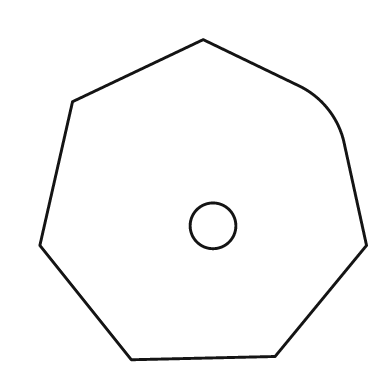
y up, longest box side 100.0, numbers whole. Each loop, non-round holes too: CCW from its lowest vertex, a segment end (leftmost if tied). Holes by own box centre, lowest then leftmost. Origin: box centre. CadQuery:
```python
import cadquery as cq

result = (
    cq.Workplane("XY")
    .moveTo(-22.0, -49.0)
    .lineTo(22.0, -48.0)
    .lineTo(50.0, -14.0)
    .lineTo(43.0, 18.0)
    .threePointArc((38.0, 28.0), (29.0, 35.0))
    .lineTo(0.0, 49.0)
    .lineTo(-40.0, 30.0)
    .lineTo(-50.0, -14.0)
    .close()
    .moveTo(3.0, -8.0)
    .circle(7.0)
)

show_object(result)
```